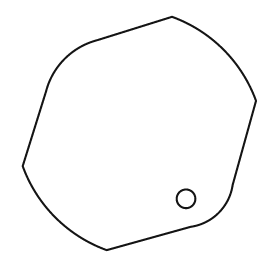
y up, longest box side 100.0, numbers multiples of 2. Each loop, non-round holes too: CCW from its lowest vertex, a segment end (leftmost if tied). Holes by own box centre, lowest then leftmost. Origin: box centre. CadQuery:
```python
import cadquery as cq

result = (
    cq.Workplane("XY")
    .moveTo(-14.0, -50.0)
    .lineTo(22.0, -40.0)
    .threePointArc((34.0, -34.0), (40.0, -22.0))
    .lineTo(50.0, 14.0)
    .threePointArc((36.0, 36.0), (14.0, 50.0))
    .lineTo(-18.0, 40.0)
    .threePointArc((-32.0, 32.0), (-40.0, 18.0))
    .lineTo(-50.0, -14.0)
    .threePointArc((-36.0, -36.0), (-14.0, -50.0))
    .close()
    .moveTo(20.0, -28.0)
    .circle(4.0)
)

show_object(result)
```